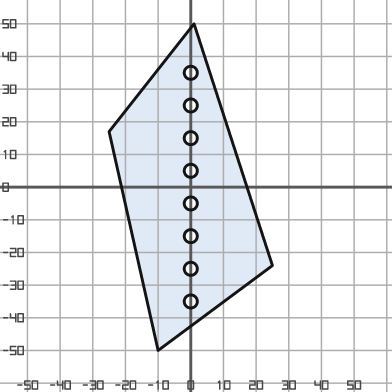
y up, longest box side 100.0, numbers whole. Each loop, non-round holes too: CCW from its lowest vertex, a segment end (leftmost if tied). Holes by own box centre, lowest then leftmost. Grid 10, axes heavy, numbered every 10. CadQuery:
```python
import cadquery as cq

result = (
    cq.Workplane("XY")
    .moveTo(-10.0, -50.0)
    .lineTo(25.0, -24.0)
    .lineTo(1.0, 50.0)
    .lineTo(-25.0, 17.0)
    .close()
    .moveTo(0.0, -35.0)
    .circle(2.0)
    .moveTo(0.0, -25.0)
    .circle(2.0)
    .moveTo(0.0, -15.0)
    .circle(2.0)
    .moveTo(0.0, -5.0)
    .circle(2.0)
    .moveTo(0.0, 5.0)
    .circle(2.0)
    .moveTo(0.0, 15.0)
    .circle(2.0)
    .moveTo(0.0, 25.0)
    .circle(2.0)
    .moveTo(0.0, 35.0)
    .circle(2.0)
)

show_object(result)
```